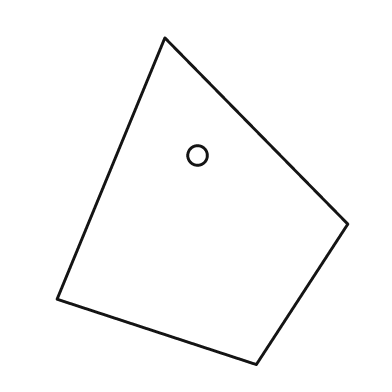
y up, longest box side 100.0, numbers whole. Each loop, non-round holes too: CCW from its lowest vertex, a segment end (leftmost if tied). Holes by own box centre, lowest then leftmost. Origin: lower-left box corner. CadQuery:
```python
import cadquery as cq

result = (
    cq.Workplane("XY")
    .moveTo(61.0, 0.0)
    .lineTo(89.0, 43.0)
    .lineTo(33.0, 100.0)
    .lineTo(0.0, 20.0)
    .close()
    .moveTo(43.0, 64.0)
    .circle(3.0)
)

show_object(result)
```